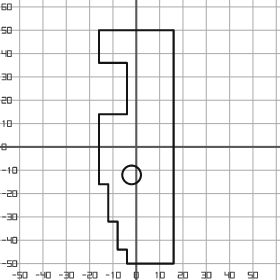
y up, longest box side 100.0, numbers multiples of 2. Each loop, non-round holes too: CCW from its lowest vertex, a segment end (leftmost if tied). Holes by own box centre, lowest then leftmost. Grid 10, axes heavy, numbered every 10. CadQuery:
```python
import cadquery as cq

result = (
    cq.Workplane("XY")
    .moveTo(-4.0, -50.0)
    .lineTo(16.0, -50.0)
    .lineTo(16.0, 50.0)
    .lineTo(-16.0, 50.0)
    .lineTo(-16.0, 36.0)
    .lineTo(-4.0, 36.0)
    .lineTo(-4.0, 14.0)
    .lineTo(-16.0, 14.0)
    .lineTo(-16.0, -16.0)
    .lineTo(-12.0, -16.0)
    .lineTo(-12.0, -32.0)
    .lineTo(-8.0, -32.0)
    .lineTo(-8.0, -44.0)
    .lineTo(-4.0, -44.0)
    .close()
    .moveTo(-2.0, -12.0)
    .circle(4.0)
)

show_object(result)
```